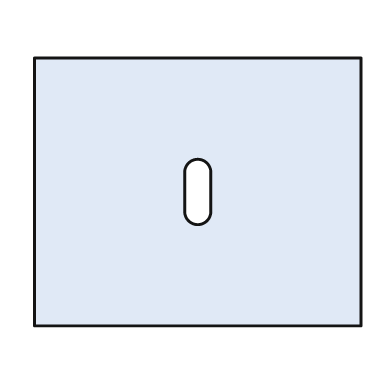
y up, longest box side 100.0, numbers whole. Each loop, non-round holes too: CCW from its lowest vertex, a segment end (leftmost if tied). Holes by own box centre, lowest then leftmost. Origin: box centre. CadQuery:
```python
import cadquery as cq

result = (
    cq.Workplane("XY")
    .moveTo(-50.0, -41.0)
    .lineTo(50.0, -41.0)
    .lineTo(50.0, 41.0)
    .lineTo(-50.0, 41.0)
    .close()
    .moveTo(-4.0, -6.0)
    .threePointArc((0.0, -10.0), (4.0, -6.0))
    .lineTo(4.0, 6.0)
    .threePointArc((0.0, 10.0), (-4.0, 6.0))
    .close()
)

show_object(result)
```